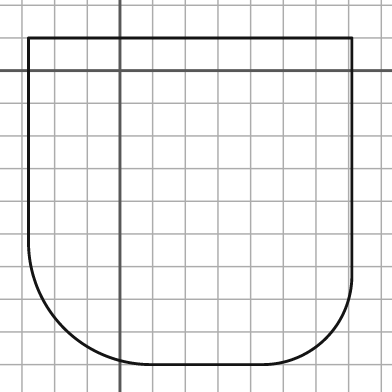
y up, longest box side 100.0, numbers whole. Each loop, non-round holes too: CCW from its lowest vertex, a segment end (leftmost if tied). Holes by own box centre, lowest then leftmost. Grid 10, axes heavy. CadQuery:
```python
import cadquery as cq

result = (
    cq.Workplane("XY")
    .moveTo(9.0, -90.0)
    .lineTo(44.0, -90.0)
    .threePointArc((63.0, -82.0), (71.0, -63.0))
    .lineTo(71.0, 10.0)
    .lineTo(-28.0, 10.0)
    .lineTo(-28.0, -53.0)
    .threePointArc((-17.0, -79.0), (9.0, -90.0))
    .close()
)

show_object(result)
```